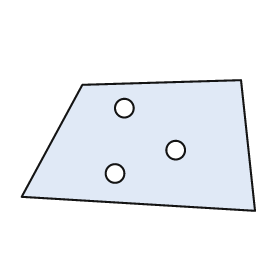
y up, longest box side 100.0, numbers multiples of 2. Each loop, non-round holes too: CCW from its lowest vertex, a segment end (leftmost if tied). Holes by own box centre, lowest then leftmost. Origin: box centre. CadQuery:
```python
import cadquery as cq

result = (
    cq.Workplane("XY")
    .moveTo(50.0, -28.0)
    .lineTo(44.0, 28.0)
    .lineTo(-24.0, 26.0)
    .lineTo(-50.0, -22.0)
    .close()
    .moveTo(-10.0, -12.0)
    .circle(4.0)
    .moveTo(16.0, -2.0)
    .circle(4.0)
    .moveTo(-6.0, 16.0)
    .circle(4.0)
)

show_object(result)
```